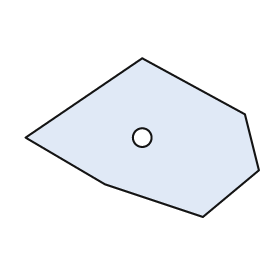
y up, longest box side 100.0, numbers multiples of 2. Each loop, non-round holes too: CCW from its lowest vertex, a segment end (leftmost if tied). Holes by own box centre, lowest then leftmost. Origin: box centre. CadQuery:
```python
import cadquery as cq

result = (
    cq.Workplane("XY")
    .moveTo(26.0, -34.0)
    .lineTo(50.0, -14.0)
    .lineTo(44.0, 10.0)
    .lineTo(0.0, 34.0)
    .lineTo(-50.0, 0.0)
    .lineTo(-16.0, -20.0)
    .close()
    .moveTo(0.0, 0.0)
    .circle(4.0)
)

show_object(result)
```